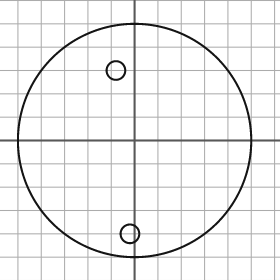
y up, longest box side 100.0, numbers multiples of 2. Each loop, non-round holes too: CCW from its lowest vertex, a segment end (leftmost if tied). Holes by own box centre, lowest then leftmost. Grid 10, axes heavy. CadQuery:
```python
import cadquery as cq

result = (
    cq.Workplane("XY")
    .moveTo(0.0, 0.0)
    .circle(50.0)
    .moveTo(-2.0, -40.0)
    .circle(4.0)
    .moveTo(-8.0, 30.0)
    .circle(4.0)
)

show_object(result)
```